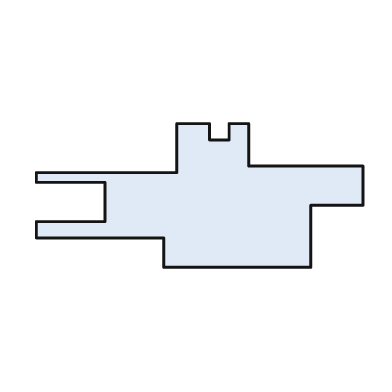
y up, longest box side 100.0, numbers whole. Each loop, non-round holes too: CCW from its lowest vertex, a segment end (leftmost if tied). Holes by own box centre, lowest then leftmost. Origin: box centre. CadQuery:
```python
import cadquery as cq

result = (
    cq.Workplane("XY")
    .moveTo(-11.0, -22.0)
    .lineTo(34.0, -22.0)
    .lineTo(34.0, -3.0)
    .lineTo(50.0, -3.0)
    .lineTo(50.0, 9.0)
    .lineTo(15.0, 9.0)
    .lineTo(15.0, 22.0)
    .lineTo(9.0, 22.0)
    .lineTo(9.0, 17.0)
    .lineTo(3.0, 17.0)
    .lineTo(3.0, 22.0)
    .lineTo(-7.0, 22.0)
    .lineTo(-7.0, 7.0)
    .lineTo(-50.0, 7.0)
    .lineTo(-50.0, 4.0)
    .lineTo(-29.0, 4.0)
    .lineTo(-29.0, -8.0)
    .lineTo(-50.0, -8.0)
    .lineTo(-50.0, -13.0)
    .lineTo(-11.0, -13.0)
    .close()
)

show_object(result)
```